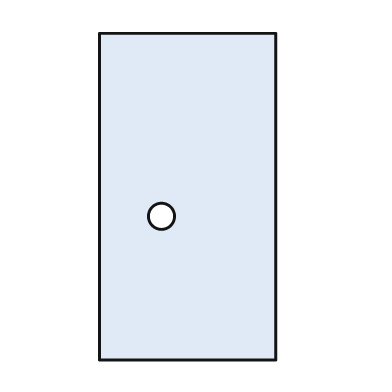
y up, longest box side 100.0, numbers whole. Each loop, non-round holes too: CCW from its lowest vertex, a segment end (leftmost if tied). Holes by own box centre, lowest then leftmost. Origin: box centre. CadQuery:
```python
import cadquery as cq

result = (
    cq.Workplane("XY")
    .moveTo(-27.0, -50.0)
    .lineTo(27.0, -50.0)
    .lineTo(27.0, 50.0)
    .lineTo(-27.0, 50.0)
    .close()
    .moveTo(-8.0, -6.0)
    .circle(4.0)
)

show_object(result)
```